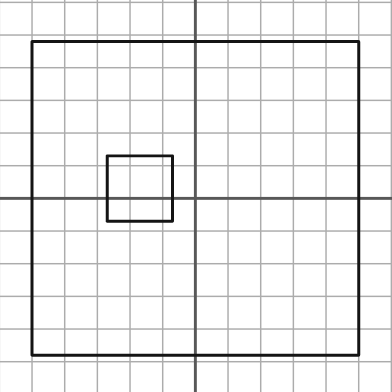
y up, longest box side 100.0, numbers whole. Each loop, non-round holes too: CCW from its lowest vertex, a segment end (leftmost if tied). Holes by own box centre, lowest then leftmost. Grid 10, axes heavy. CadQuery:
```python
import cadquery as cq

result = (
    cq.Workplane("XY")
    .moveTo(-50.0, -48.0)
    .lineTo(50.0, -48.0)
    .lineTo(50.0, 48.0)
    .lineTo(-50.0, 48.0)
    .close()
    .moveTo(-27.0, -7.0)
    .lineTo(-7.0, -7.0)
    .lineTo(-7.0, 13.0)
    .lineTo(-27.0, 13.0)
    .close()
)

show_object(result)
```